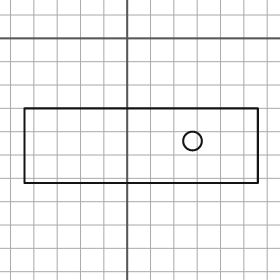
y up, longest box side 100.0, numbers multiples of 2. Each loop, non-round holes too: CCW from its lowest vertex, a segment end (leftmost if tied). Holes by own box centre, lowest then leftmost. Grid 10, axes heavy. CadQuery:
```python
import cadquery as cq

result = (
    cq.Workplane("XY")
    .moveTo(-44.0, -62.0)
    .lineTo(56.0, -62.0)
    .lineTo(56.0, -30.0)
    .lineTo(-44.0, -30.0)
    .close()
    .moveTo(28.0, -44.0)
    .circle(4.0)
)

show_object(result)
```